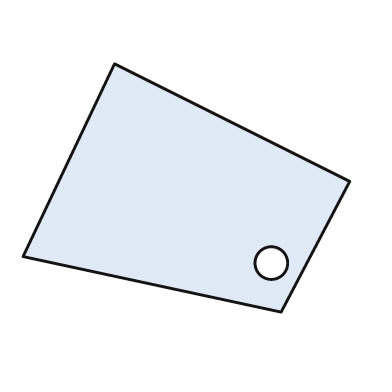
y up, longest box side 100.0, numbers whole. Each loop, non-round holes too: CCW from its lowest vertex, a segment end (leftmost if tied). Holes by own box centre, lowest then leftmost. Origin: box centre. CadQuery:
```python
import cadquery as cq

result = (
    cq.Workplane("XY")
    .moveTo(29.0, -38.0)
    .lineTo(50.0, 2.0)
    .lineTo(-22.0, 38.0)
    .lineTo(-50.0, -21.0)
    .close()
    .moveTo(26.0, -23.0)
    .circle(5.0)
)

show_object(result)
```